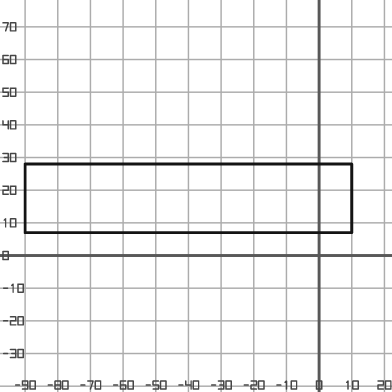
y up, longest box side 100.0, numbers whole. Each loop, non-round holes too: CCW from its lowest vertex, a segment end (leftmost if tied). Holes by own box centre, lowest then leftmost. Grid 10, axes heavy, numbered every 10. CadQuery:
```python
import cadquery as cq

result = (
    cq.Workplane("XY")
    .moveTo(-90.0, 7.0)
    .lineTo(10.0, 7.0)
    .lineTo(10.0, 28.0)
    .lineTo(-90.0, 28.0)
    .close()
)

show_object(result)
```